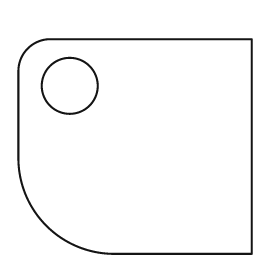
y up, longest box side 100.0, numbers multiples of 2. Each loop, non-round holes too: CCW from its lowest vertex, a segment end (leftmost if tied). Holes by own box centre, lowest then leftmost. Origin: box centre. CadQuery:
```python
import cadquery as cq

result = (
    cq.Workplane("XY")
    .moveTo(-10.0, -46.0)
    .lineTo(50.0, -46.0)
    .lineTo(50.0, 46.0)
    .lineTo(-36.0, 46.0)
    .threePointArc((-46.0, 42.0), (-50.0, 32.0))
    .lineTo(-50.0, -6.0)
    .threePointArc((-38.0, -34.0), (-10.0, -46.0))
    .close()
    .moveTo(-28.0, 26.0)
    .circle(12.0)
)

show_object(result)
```